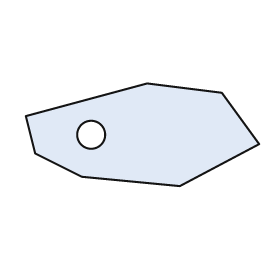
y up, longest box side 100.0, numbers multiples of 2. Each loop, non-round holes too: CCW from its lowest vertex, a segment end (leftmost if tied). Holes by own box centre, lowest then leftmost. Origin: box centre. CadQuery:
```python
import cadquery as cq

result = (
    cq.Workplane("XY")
    .moveTo(16.0, -22.0)
    .lineTo(50.0, -4.0)
    .lineTo(34.0, 18.0)
    .lineTo(2.0, 22.0)
    .lineTo(-50.0, 8.0)
    .lineTo(-46.0, -8.0)
    .lineTo(-26.0, -18.0)
    .close()
    .moveTo(-22.0, 0.0)
    .circle(6.0)
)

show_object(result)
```